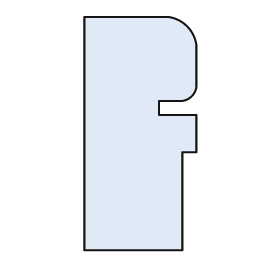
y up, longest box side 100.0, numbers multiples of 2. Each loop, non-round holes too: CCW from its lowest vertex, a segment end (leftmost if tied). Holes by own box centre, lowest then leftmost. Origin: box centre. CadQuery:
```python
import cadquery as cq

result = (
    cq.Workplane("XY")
    .moveTo(-24.0, -50.0)
    .lineTo(18.0, -50.0)
    .lineTo(18.0, -8.0)
    .lineTo(24.0, -8.0)
    .lineTo(24.0, 8.0)
    .lineTo(8.0, 8.0)
    .lineTo(8.0, 14.0)
    .lineTo(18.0, 14.0)
    .threePointArc((22.0, 16.0), (24.0, 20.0))
    .lineTo(24.0, 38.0)
    .threePointArc((20.0, 46.0), (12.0, 50.0))
    .lineTo(-24.0, 50.0)
    .close()
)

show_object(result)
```